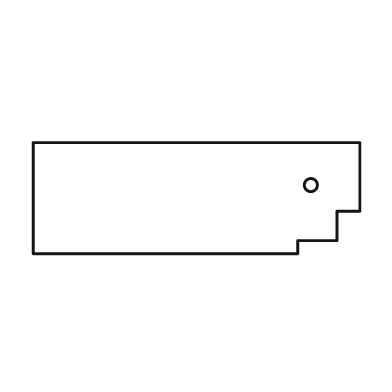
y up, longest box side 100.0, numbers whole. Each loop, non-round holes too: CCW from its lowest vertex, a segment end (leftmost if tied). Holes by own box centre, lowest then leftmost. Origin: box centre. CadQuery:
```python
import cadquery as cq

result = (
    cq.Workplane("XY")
    .moveTo(-50.0, -17.0)
    .lineTo(31.0, -17.0)
    .lineTo(31.0, -13.0)
    .lineTo(43.0, -13.0)
    .lineTo(43.0, -4.0)
    .lineTo(50.0, -4.0)
    .lineTo(50.0, 17.0)
    .lineTo(-50.0, 17.0)
    .close()
    .moveTo(35.0, 4.0)
    .circle(2.0)
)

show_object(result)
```